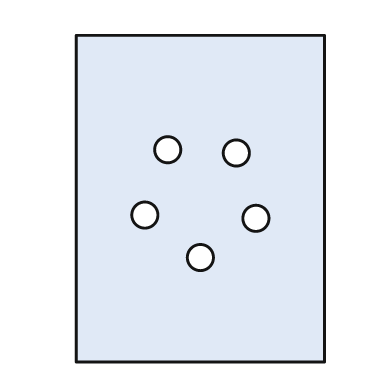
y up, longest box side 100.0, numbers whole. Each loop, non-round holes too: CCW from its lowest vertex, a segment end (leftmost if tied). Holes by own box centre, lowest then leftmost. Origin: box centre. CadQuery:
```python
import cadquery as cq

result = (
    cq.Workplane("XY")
    .moveTo(-38.0, -50.0)
    .lineTo(38.0, -50.0)
    .lineTo(38.0, 50.0)
    .lineTo(-38.0, 50.0)
    .close()
    .moveTo(0.0, -18.0)
    .circle(4.0)
    .moveTo(17.0, -6.0)
    .circle(4.0)
    .moveTo(-17.0, -5.0)
    .circle(4.0)
    .moveTo(11.0, 14.0)
    .circle(4.0)
    .moveTo(-10.0, 15.0)
    .circle(4.0)
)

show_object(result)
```